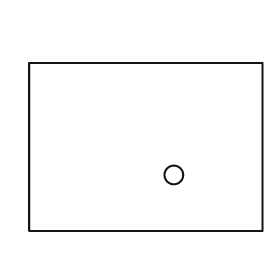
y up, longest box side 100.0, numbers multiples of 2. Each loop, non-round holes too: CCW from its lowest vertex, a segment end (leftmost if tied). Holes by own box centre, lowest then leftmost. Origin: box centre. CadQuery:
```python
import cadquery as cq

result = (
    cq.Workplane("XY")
    .moveTo(-50.0, -36.0)
    .lineTo(50.0, -36.0)
    .lineTo(50.0, 36.0)
    .lineTo(-50.0, 36.0)
    .close()
    .moveTo(12.0, -12.0)
    .circle(4.0)
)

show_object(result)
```